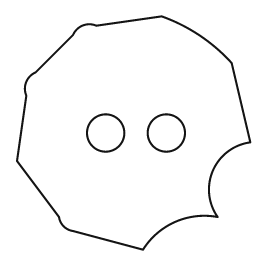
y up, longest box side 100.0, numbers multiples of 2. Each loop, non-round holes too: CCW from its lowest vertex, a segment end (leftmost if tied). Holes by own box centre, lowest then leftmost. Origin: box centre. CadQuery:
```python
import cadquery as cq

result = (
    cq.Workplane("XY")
    .moveTo(4.0, -50.0)
    .threePointArc((18.0, -38.0), (36.0, -36.0))
    .threePointArc((34.0, -16.0), (50.0, -4.0))
    .lineTo(42.0, 30.0)
    .threePointArc((28.0, 42.0), (12.0, 50.0))
    .lineTo(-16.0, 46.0)
    .threePointArc((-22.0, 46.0), (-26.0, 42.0))
    .lineTo(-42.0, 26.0)
    .threePointArc((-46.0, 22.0), (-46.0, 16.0))
    .lineTo(-50.0, -12.0)
    .lineTo(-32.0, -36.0)
    .threePointArc((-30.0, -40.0), (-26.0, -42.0))
    .close()
    .moveTo(-12.0, 0.0)
    .circle(8.0)
    .moveTo(14.0, 0.0)
    .circle(8.0)
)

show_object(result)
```